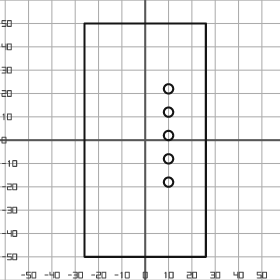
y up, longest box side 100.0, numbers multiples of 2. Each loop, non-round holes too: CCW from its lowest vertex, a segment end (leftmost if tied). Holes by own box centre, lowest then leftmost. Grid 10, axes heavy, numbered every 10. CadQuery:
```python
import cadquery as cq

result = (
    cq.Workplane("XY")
    .moveTo(-26.0, -50.0)
    .lineTo(26.0, -50.0)
    .lineTo(26.0, 50.0)
    .lineTo(-26.0, 50.0)
    .close()
    .moveTo(10.0, -18.0)
    .circle(2.0)
    .moveTo(10.0, -8.0)
    .circle(2.0)
    .moveTo(10.0, 2.0)
    .circle(2.0)
    .moveTo(10.0, 12.0)
    .circle(2.0)
    .moveTo(10.0, 22.0)
    .circle(2.0)
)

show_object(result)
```